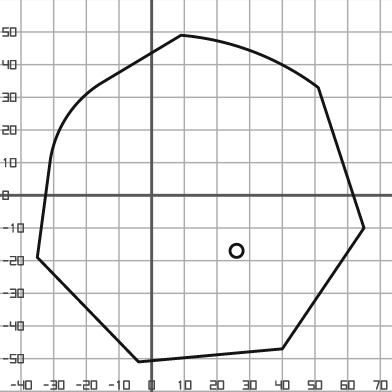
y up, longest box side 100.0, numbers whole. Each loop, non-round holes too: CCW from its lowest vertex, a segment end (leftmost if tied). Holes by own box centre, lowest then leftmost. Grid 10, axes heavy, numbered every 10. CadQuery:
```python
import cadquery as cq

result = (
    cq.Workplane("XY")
    .moveTo(-4.0, -51.0)
    .lineTo(40.0, -47.0)
    .lineTo(65.0, -10.0)
    .lineTo(51.0, 33.0)
    .threePointArc((31.0, 44.0), (9.0, 49.0))
    .lineTo(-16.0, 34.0)
    .threePointArc((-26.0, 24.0), (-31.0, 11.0))
    .lineTo(-35.0, -19.0)
    .close()
    .moveTo(26.0, -17.0)
    .circle(2.0)
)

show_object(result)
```